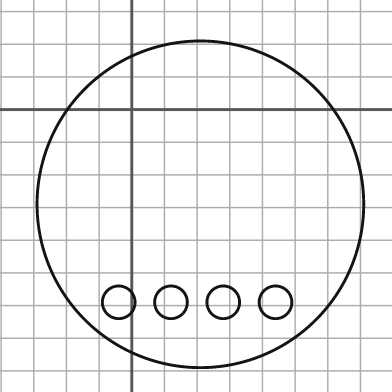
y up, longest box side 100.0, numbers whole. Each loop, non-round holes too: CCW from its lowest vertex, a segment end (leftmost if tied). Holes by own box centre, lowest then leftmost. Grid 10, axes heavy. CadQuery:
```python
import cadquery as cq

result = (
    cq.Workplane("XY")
    .moveTo(21.0, -29.0)
    .circle(50.0)
    .moveTo(-4.0, -59.0)
    .circle(5.0)
    .moveTo(12.0, -59.0)
    .circle(5.0)
    .moveTo(28.0, -59.0)
    .circle(5.0)
    .moveTo(44.0, -59.0)
    .circle(5.0)
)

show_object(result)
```